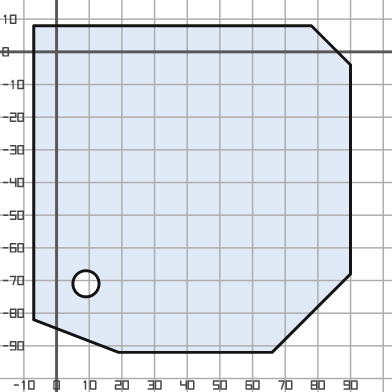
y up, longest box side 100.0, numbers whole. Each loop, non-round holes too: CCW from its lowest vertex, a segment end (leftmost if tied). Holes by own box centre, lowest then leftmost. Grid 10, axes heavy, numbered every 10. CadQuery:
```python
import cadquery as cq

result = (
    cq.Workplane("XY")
    .moveTo(19.0, -92.0)
    .lineTo(66.0, -92.0)
    .lineTo(90.0, -68.0)
    .lineTo(90.0, -4.0)
    .lineTo(78.0, 8.0)
    .lineTo(-7.0, 8.0)
    .lineTo(-7.0, -82.0)
    .close()
    .moveTo(9.0, -71.0)
    .circle(4.0)
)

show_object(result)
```